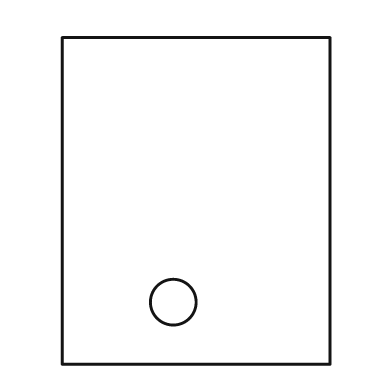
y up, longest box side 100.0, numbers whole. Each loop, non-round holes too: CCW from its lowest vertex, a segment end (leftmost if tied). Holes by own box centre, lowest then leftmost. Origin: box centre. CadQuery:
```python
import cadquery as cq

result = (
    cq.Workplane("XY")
    .moveTo(-41.0, -50.0)
    .lineTo(41.0, -50.0)
    .lineTo(41.0, 50.0)
    .lineTo(-41.0, 50.0)
    .close()
    .moveTo(-7.0, -31.0)
    .circle(7.0)
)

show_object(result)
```